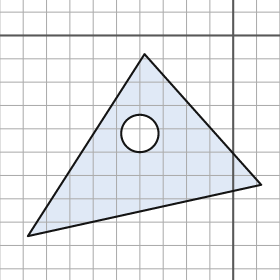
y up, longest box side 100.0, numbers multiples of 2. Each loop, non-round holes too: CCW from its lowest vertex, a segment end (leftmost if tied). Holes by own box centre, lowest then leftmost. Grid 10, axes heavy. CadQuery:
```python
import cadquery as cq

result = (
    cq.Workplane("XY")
    .moveTo(-88.0, -86.0)
    .lineTo(12.0, -64.0)
    .lineTo(-38.0, -8.0)
    .close()
    .moveTo(-40.0, -42.0)
    .circle(8.0)
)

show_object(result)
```